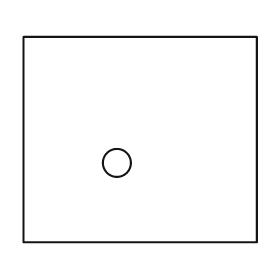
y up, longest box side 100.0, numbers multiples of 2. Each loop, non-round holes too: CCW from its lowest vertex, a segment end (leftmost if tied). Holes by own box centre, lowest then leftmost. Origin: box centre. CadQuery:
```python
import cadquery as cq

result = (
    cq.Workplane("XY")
    .moveTo(-50.0, -44.0)
    .lineTo(50.0, -44.0)
    .lineTo(50.0, 44.0)
    .lineTo(-50.0, 44.0)
    .close()
    .moveTo(-10.0, -10.0)
    .circle(6.0)
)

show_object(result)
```